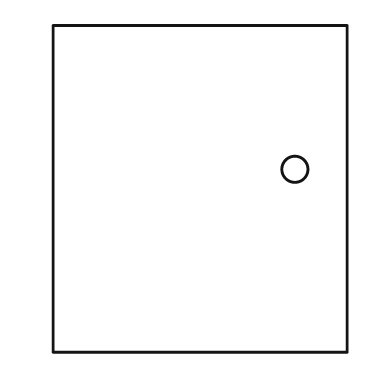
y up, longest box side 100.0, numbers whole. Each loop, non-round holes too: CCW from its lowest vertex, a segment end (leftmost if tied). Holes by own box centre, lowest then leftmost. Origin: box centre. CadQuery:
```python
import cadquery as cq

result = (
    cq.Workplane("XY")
    .moveTo(-45.0, -50.0)
    .lineTo(45.0, -50.0)
    .lineTo(45.0, 50.0)
    .lineTo(-45.0, 50.0)
    .close()
    .moveTo(29.0, 6.0)
    .circle(4.0)
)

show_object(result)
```